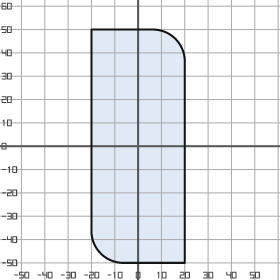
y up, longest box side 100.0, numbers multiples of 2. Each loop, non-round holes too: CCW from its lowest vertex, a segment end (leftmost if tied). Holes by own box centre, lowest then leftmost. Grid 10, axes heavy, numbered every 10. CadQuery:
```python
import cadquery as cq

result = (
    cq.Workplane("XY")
    .moveTo(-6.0, -50.0)
    .lineTo(20.0, -50.0)
    .lineTo(20.0, 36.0)
    .threePointArc((16.0, 46.0), (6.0, 50.0))
    .lineTo(-20.0, 50.0)
    .lineTo(-20.0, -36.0)
    .threePointArc((-16.0, -46.0), (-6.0, -50.0))
    .close()
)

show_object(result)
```